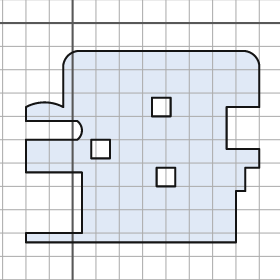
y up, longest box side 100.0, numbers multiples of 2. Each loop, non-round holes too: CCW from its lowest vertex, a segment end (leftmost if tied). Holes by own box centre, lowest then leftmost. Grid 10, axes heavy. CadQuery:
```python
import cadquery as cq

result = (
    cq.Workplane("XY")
    .moveTo(-20.0, -94.0)
    .lineTo(70.0, -94.0)
    .lineTo(70.0, -72.0)
    .lineTo(74.0, -72.0)
    .lineTo(74.0, -62.0)
    .lineTo(80.0, -62.0)
    .lineTo(80.0, -54.0)
    .lineTo(66.0, -54.0)
    .lineTo(66.0, -36.0)
    .lineTo(80.0, -36.0)
    .lineTo(80.0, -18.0)
    .threePointArc((78.0, -14.0), (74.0, -12.0))
    .lineTo(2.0, -12.0)
    .threePointArc((-2.0, -14.0), (-4.0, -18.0))
    .lineTo(-4.0, -36.0)
    .threePointArc((-12.0, -34.0), (-20.0, -36.0))
    .lineTo(-20.0, -42.0)
    .lineTo(2.0, -42.0)
    .threePointArc((4.0, -46.0), (2.0, -50.0))
    .lineTo(-20.0, -50.0)
    .lineTo(-20.0, -64.0)
    .lineTo(4.0, -64.0)
    .lineTo(4.0, -90.0)
    .lineTo(-20.0, -90.0)
    .close()
    .moveTo(36.0, -70.0)
    .lineTo(44.0, -70.0)
    .lineTo(44.0, -62.0)
    .lineTo(36.0, -62.0)
    .close()
    .moveTo(8.0, -58.0)
    .lineTo(16.0, -58.0)
    .lineTo(16.0, -50.0)
    .lineTo(8.0, -50.0)
    .close()
    .moveTo(34.0, -40.0)
    .lineTo(42.0, -40.0)
    .lineTo(42.0, -32.0)
    .lineTo(34.0, -32.0)
    .close()
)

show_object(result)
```